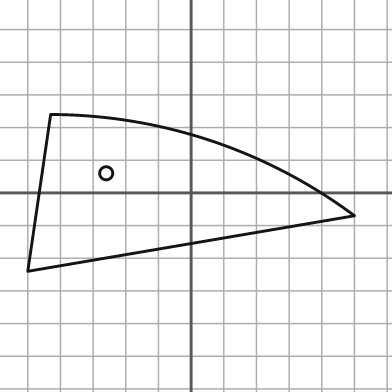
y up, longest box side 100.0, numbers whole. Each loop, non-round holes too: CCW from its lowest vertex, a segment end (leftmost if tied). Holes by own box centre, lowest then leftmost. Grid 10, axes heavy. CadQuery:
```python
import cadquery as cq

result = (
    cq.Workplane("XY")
    .moveTo(-50.0, -24.0)
    .lineTo(50.0, -7.0)
    .threePointArc((6.0, 16.0), (-43.0, 24.0))
    .close()
    .moveTo(-26.0, 6.0)
    .circle(2.0)
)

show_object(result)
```